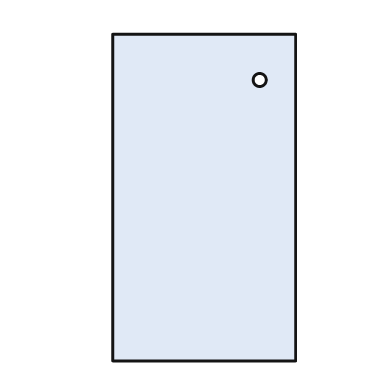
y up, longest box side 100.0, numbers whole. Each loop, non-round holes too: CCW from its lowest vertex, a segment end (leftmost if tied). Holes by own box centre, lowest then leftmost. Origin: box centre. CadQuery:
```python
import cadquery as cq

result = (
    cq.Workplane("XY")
    .moveTo(-28.0, -50.0)
    .lineTo(28.0, -50.0)
    .lineTo(28.0, 50.0)
    .lineTo(-28.0, 50.0)
    .close()
    .moveTo(17.0, 36.0)
    .circle(2.0)
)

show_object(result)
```